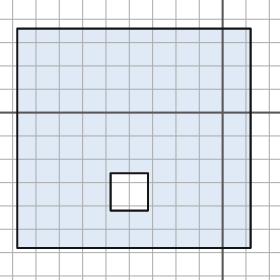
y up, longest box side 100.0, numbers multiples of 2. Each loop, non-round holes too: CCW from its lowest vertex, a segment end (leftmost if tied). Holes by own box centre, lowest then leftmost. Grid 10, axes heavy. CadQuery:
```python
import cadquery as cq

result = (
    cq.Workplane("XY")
    .moveTo(-88.0, -58.0)
    .lineTo(12.0, -58.0)
    .lineTo(12.0, 36.0)
    .lineTo(-88.0, 36.0)
    .close()
    .moveTo(-48.0, -42.0)
    .lineTo(-32.0, -42.0)
    .lineTo(-32.0, -26.0)
    .lineTo(-48.0, -26.0)
    .close()
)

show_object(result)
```